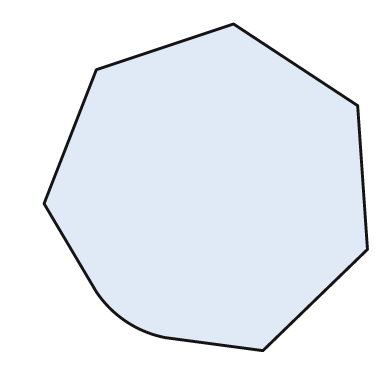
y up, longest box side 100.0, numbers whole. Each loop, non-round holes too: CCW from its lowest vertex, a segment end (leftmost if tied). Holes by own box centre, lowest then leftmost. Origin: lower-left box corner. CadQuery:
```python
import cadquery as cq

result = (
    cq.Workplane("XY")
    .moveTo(67.0, 0.0)
    .lineTo(99.0, 31.0)
    .lineTo(96.0, 75.0)
    .lineTo(58.0, 100.0)
    .lineTo(16.0, 86.0)
    .lineTo(0.0, 45.0)
    .lineTo(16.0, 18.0)
    .threePointArc((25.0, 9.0), (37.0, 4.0))
    .close()
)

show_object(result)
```